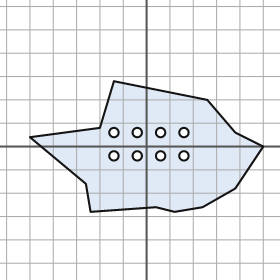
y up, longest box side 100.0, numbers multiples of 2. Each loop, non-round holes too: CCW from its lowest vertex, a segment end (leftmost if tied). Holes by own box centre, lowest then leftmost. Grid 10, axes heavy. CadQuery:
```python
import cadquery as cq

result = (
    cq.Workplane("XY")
    .moveTo(-24.0, -28.0)
    .lineTo(4.0, -26.0)
    .lineTo(12.0, -28.0)
    .lineTo(24.0, -26.0)
    .lineTo(38.0, -18.0)
    .lineTo(50.0, 0.0)
    .lineTo(38.0, 6.0)
    .lineTo(26.0, 20.0)
    .lineTo(-14.0, 28.0)
    .lineTo(-20.0, 8.0)
    .lineTo(-50.0, 4.0)
    .lineTo(-26.0, -16.0)
    .close()
    .moveTo(-14.0, -4.0)
    .circle(2.0)
    .moveTo(-4.0, -4.0)
    .circle(2.0)
    .moveTo(6.0, -4.0)
    .circle(2.0)
    .moveTo(16.0, -4.0)
    .circle(2.0)
    .moveTo(-14.0, 6.0)
    .circle(2.0)
    .moveTo(-4.0, 6.0)
    .circle(2.0)
    .moveTo(6.0, 6.0)
    .circle(2.0)
    .moveTo(16.0, 6.0)
    .circle(2.0)
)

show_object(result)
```